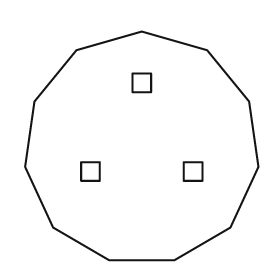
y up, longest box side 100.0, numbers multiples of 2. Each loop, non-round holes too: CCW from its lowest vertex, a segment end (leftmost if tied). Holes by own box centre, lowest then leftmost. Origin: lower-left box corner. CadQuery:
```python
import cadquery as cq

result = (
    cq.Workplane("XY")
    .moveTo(36.0, 0.0)
    .lineTo(64.0, 0.0)
    .lineTo(88.0, 14.0)
    .lineTo(100.0, 40.0)
    .lineTo(96.0, 68.0)
    .lineTo(78.0, 90.0)
    .lineTo(50.0, 98.0)
    .lineTo(22.0, 90.0)
    .lineTo(4.0, 68.0)
    .lineTo(0.0, 40.0)
    .lineTo(12.0, 14.0)
    .close()
    .moveTo(24.0, 34.0)
    .lineTo(32.0, 34.0)
    .lineTo(32.0, 42.0)
    .lineTo(24.0, 42.0)
    .close()
    .moveTo(68.0, 34.0)
    .lineTo(76.0, 34.0)
    .lineTo(76.0, 42.0)
    .lineTo(68.0, 42.0)
    .close()
    .moveTo(46.0, 72.0)
    .lineTo(54.0, 72.0)
    .lineTo(54.0, 80.0)
    .lineTo(46.0, 80.0)
    .close()
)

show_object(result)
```